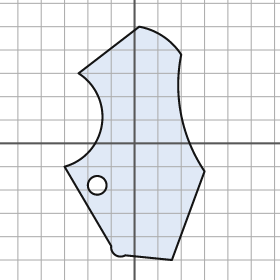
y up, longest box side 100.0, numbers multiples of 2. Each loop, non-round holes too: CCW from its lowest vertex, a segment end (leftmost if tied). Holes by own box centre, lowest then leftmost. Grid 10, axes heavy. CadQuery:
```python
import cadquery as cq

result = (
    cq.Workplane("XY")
    .moveTo(16.0, -50.0)
    .lineTo(30.0, -12.0)
    .threePointArc((20.0, 12.0), (20.0, 38.0))
    .threePointArc((12.0, 46.0), (2.0, 50.0))
    .lineTo(-24.0, 30.0)
    .threePointArc((-14.0, 8.0), (-30.0, -10.0))
    .lineTo(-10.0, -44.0)
    .threePointArc((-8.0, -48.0), (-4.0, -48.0))
    .close()
    .moveTo(-16.0, -18.0)
    .circle(4.0)
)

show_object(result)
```